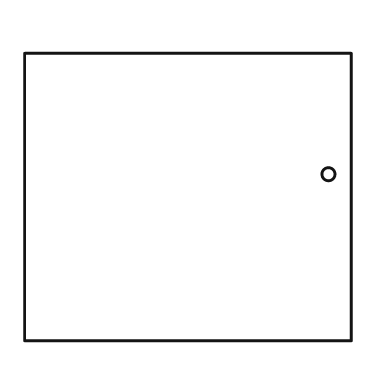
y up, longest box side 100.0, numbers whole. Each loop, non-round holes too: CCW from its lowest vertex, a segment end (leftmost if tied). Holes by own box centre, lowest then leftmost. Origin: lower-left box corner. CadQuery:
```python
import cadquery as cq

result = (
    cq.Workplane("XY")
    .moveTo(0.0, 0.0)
    .lineTo(100.0, 0.0)
    .lineTo(100.0, 88.0)
    .lineTo(0.0, 88.0)
    .close()
    .moveTo(93.0, 51.0)
    .circle(2.0)
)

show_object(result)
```